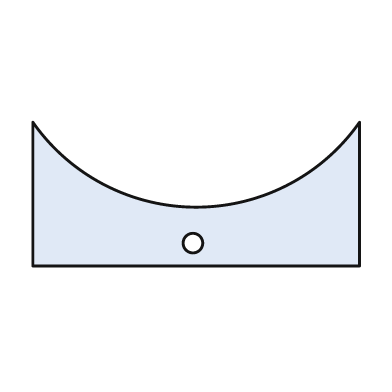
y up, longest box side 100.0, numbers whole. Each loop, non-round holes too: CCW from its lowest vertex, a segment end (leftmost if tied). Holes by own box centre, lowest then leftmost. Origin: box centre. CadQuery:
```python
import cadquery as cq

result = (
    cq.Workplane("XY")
    .moveTo(-50.0, -22.0)
    .lineTo(50.0, -22.0)
    .lineTo(50.0, 22.0)
    .threePointArc((0.0, -4.0), (-50.0, 22.0))
    .close()
    .moveTo(-1.0, -15.0)
    .circle(3.0)
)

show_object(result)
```